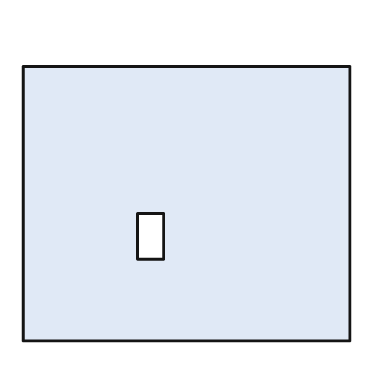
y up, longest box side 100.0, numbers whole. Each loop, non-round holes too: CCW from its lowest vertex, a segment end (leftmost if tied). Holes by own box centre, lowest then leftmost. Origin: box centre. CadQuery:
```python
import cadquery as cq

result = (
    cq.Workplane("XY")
    .moveTo(-50.0, -42.0)
    .lineTo(50.0, -42.0)
    .lineTo(50.0, 42.0)
    .lineTo(-50.0, 42.0)
    .close()
    .moveTo(-15.0, -17.0)
    .lineTo(-7.0, -17.0)
    .lineTo(-7.0, -3.0)
    .lineTo(-15.0, -3.0)
    .close()
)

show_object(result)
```